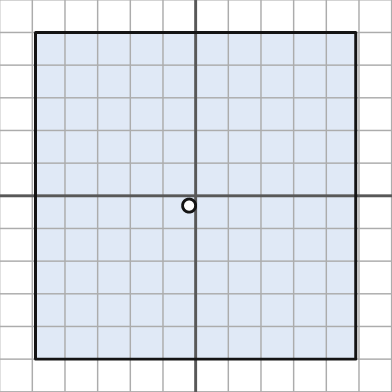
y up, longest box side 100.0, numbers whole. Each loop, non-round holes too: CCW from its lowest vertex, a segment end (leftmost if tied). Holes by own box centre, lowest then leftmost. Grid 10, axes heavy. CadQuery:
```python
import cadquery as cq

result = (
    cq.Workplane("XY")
    .moveTo(-49.0, -50.0)
    .lineTo(49.0, -50.0)
    .lineTo(49.0, 50.0)
    .lineTo(-49.0, 50.0)
    .close()
    .moveTo(-2.0, -3.0)
    .circle(2.0)
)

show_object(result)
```